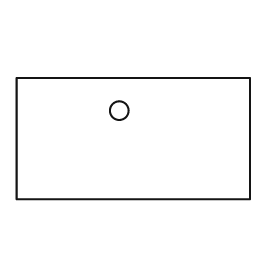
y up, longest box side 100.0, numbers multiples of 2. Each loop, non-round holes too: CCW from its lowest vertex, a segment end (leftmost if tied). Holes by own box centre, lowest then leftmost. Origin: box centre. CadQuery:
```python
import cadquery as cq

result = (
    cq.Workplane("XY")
    .moveTo(-50.0, -26.0)
    .lineTo(50.0, -26.0)
    .lineTo(50.0, 26.0)
    .lineTo(-50.0, 26.0)
    .close()
    .moveTo(-6.0, 12.0)
    .circle(4.0)
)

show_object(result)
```